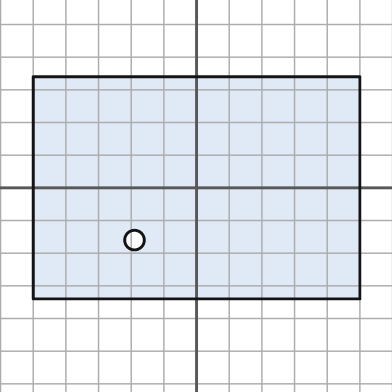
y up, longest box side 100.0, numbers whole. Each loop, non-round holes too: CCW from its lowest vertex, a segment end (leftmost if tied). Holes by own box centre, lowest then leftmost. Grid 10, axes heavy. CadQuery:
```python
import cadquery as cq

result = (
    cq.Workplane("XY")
    .moveTo(-50.0, -34.0)
    .lineTo(50.0, -34.0)
    .lineTo(50.0, 34.0)
    .lineTo(-50.0, 34.0)
    .close()
    .moveTo(-19.0, -16.0)
    .circle(3.0)
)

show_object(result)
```